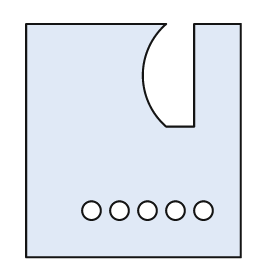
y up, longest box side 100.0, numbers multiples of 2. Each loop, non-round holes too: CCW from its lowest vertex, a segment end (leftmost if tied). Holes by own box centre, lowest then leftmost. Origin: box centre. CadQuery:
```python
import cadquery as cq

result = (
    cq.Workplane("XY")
    .moveTo(-46.0, -50.0)
    .lineTo(46.0, -50.0)
    .lineTo(46.0, 50.0)
    .lineTo(26.0, 50.0)
    .lineTo(26.0, 6.0)
    .lineTo(14.0, 6.0)
    .threePointArc((4.0, 28.0), (14.0, 50.0))
    .lineTo(-46.0, 50.0)
    .close()
    .moveTo(-18.0, -30.0)
    .circle(4.0)
    .moveTo(-6.0, -30.0)
    .circle(4.0)
    .moveTo(6.0, -30.0)
    .circle(4.0)
    .moveTo(18.0, -30.0)
    .circle(4.0)
    .moveTo(30.0, -30.0)
    .circle(4.0)
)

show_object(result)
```